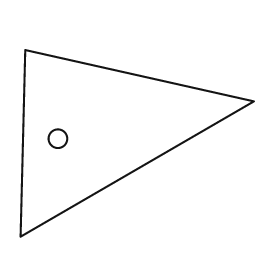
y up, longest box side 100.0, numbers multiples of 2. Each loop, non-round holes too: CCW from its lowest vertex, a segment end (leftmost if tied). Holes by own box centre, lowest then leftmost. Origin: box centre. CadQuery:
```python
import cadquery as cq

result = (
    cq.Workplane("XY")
    .moveTo(-50.0, -40.0)
    .lineTo(50.0, 18.0)
    .lineTo(-48.0, 40.0)
    .close()
    .moveTo(-34.0, 2.0)
    .circle(4.0)
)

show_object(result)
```